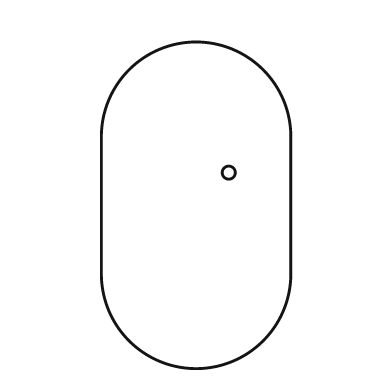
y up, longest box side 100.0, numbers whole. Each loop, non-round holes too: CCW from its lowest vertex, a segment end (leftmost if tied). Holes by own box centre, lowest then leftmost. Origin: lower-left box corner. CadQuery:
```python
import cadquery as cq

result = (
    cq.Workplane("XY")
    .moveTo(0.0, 29.0)
    .threePointArc((29.0, 0.0), (58.0, 29.0))
    .lineTo(58.0, 71.0)
    .threePointArc((29.0, 100.0), (0.0, 71.0))
    .close()
    .moveTo(39.0, 60.0)
    .circle(2.0)
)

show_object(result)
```